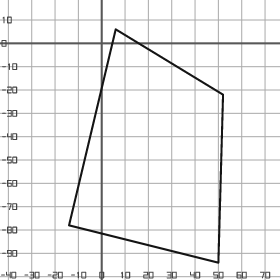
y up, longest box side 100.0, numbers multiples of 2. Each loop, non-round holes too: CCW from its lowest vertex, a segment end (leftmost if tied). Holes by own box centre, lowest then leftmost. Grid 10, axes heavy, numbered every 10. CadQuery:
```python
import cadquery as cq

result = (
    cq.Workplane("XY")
    .moveTo(50.0, -94.0)
    .lineTo(52.0, -22.0)
    .lineTo(6.0, 6.0)
    .lineTo(-14.0, -78.0)
    .close()
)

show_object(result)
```